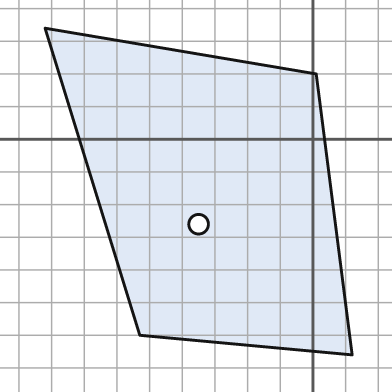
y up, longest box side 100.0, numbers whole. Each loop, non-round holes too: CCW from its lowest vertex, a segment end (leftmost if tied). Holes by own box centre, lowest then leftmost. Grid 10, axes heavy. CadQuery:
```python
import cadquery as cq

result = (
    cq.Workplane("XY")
    .moveTo(12.0, -66.0)
    .lineTo(1.0, 20.0)
    .lineTo(-82.0, 34.0)
    .lineTo(-53.0, -60.0)
    .close()
    .moveTo(-35.0, -26.0)
    .circle(3.0)
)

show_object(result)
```